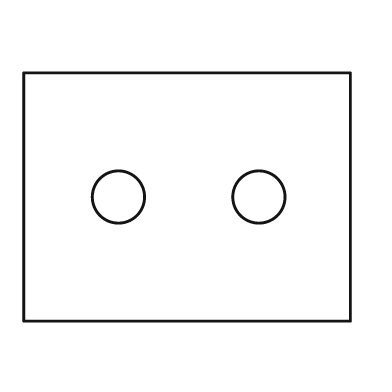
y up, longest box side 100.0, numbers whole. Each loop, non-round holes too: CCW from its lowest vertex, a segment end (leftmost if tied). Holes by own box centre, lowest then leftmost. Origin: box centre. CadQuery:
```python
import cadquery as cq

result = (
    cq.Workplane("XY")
    .moveTo(-50.0, -38.0)
    .lineTo(50.0, -38.0)
    .lineTo(50.0, 38.0)
    .lineTo(-50.0, 38.0)
    .close()
    .moveTo(-21.0, 0.0)
    .circle(8.0)
    .moveTo(22.0, 0.0)
    .circle(8.0)
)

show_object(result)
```